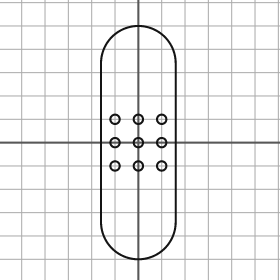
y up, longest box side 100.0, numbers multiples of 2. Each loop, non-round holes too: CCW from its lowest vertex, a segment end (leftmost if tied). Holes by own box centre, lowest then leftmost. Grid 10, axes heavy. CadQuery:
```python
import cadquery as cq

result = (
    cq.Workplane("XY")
    .moveTo(-16.0, -34.0)
    .threePointArc((0.0, -50.0), (16.0, -34.0))
    .lineTo(16.0, 34.0)
    .threePointArc((0.0, 50.0), (-16.0, 34.0))
    .close()
    .moveTo(-10.0, -10.0)
    .circle(2.0)
    .moveTo(0.0, -10.0)
    .circle(2.0)
    .moveTo(10.0, -10.0)
    .circle(2.0)
    .moveTo(-10.0, 0.0)
    .circle(2.0)
    .moveTo(0.0, 0.0)
    .circle(2.0)
    .moveTo(10.0, 0.0)
    .circle(2.0)
    .moveTo(-10.0, 10.0)
    .circle(2.0)
    .moveTo(0.0, 10.0)
    .circle(2.0)
    .moveTo(10.0, 10.0)
    .circle(2.0)
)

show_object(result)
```